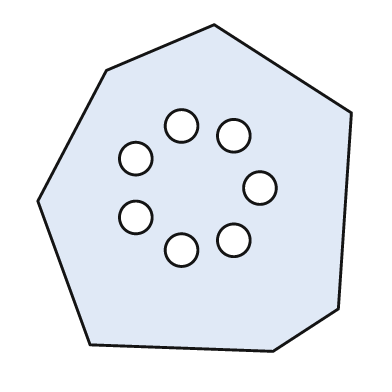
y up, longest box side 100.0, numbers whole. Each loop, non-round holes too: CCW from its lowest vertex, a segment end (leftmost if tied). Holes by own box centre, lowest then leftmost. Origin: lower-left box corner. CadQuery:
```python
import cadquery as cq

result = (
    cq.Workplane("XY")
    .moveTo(72.0, 0.0)
    .lineTo(92.0, 13.0)
    .lineTo(96.0, 73.0)
    .lineTo(54.0, 100.0)
    .lineTo(21.0, 86.0)
    .lineTo(0.0, 46.0)
    .lineTo(16.0, 2.0)
    .close()
    .moveTo(44.0, 31.0)
    .circle(5.0)
    .moveTo(60.0, 34.0)
    .circle(5.0)
    .moveTo(30.0, 41.0)
    .circle(5.0)
    .moveTo(68.0, 50.0)
    .circle(5.0)
    .moveTo(30.0, 59.0)
    .circle(5.0)
    .moveTo(60.0, 66.0)
    .circle(5.0)
    .moveTo(44.0, 69.0)
    .circle(5.0)
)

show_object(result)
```